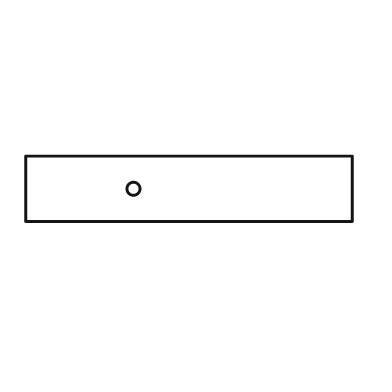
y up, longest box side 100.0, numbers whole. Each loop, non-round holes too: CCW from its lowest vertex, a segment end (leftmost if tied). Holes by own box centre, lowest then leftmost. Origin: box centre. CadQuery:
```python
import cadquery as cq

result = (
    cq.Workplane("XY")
    .moveTo(-50.0, -10.0)
    .lineTo(50.0, -10.0)
    .lineTo(50.0, 10.0)
    .lineTo(-50.0, 10.0)
    .close()
    .moveTo(-17.0, 0.0)
    .circle(2.0)
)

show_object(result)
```